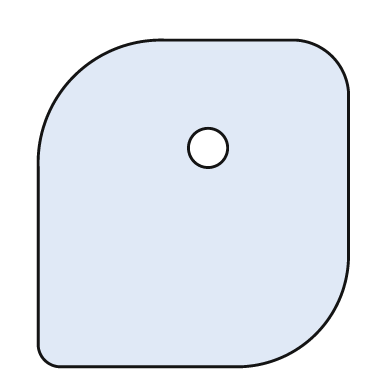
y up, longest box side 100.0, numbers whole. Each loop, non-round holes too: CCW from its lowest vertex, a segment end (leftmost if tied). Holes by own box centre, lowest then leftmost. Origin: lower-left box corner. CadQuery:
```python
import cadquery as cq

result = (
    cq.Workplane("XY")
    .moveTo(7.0, 0.0)
    .lineTo(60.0, 0.0)
    .threePointArc((85.0, 10.0), (95.0, 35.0))
    .lineTo(95.0, 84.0)
    .threePointArc((90.0, 95.0), (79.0, 100.0))
    .lineTo(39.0, 100.0)
    .threePointArc((11.0, 89.0), (0.0, 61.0))
    .lineTo(0.0, 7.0)
    .threePointArc((2.0, 2.0), (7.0, 0.0))
    .close()
    .moveTo(52.0, 67.0)
    .circle(6.0)
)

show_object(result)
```